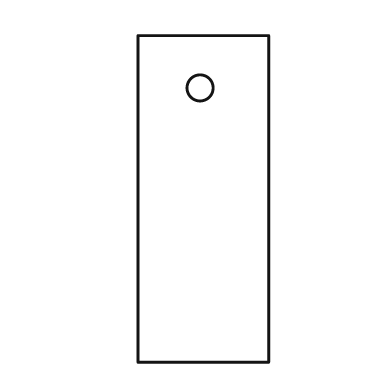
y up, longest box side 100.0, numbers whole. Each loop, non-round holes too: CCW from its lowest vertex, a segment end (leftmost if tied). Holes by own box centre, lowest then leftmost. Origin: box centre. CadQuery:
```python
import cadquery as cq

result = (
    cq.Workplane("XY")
    .moveTo(-20.0, -50.0)
    .lineTo(20.0, -50.0)
    .lineTo(20.0, 50.0)
    .lineTo(-20.0, 50.0)
    .close()
    .moveTo(-1.0, 34.0)
    .circle(4.0)
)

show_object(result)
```